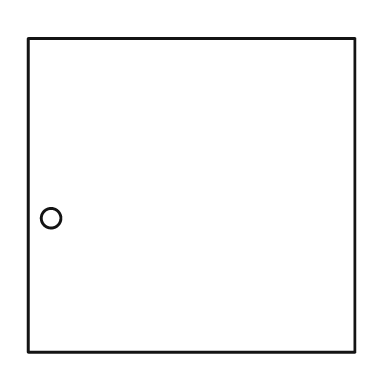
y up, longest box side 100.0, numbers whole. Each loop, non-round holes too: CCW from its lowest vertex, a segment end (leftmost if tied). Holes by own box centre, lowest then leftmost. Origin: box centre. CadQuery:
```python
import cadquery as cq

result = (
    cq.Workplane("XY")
    .moveTo(-50.0, -48.0)
    .lineTo(50.0, -48.0)
    .lineTo(50.0, 48.0)
    .lineTo(-50.0, 48.0)
    .close()
    .moveTo(-43.0, -7.0)
    .circle(3.0)
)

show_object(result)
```